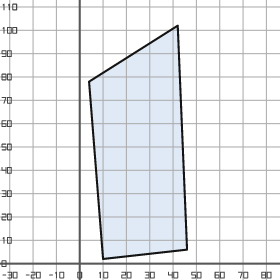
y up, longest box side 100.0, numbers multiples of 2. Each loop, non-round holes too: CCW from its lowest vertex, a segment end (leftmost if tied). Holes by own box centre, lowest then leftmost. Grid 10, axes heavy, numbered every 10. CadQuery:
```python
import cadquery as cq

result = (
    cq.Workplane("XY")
    .moveTo(10.0, 2.0)
    .lineTo(46.0, 6.0)
    .lineTo(42.0, 102.0)
    .lineTo(4.0, 78.0)
    .close()
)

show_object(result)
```